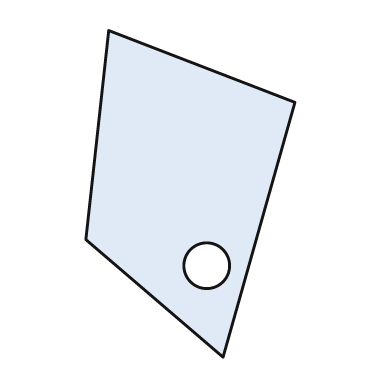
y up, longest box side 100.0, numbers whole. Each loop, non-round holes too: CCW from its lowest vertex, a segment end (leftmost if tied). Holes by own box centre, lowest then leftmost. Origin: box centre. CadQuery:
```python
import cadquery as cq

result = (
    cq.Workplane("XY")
    .moveTo(10.0, -50.0)
    .lineTo(32.0, 28.0)
    .lineTo(-25.0, 50.0)
    .lineTo(-32.0, -14.0)
    .close()
    .moveTo(5.0, -22.0)
    .circle(7.0)
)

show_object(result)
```